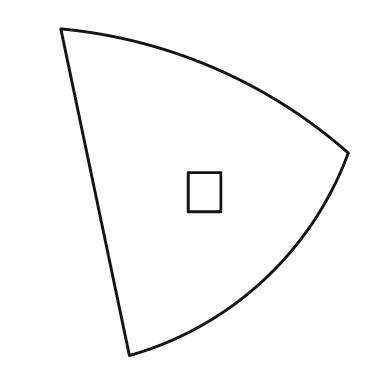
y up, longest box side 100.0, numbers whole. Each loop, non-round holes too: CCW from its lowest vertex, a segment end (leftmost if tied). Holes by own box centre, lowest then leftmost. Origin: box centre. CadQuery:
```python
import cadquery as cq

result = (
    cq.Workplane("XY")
    .moveTo(-23.0, -50.0)
    .threePointArc((18.0, -27.0), (44.0, 12.0))
    .threePointArc((3.0, 38.0), (-44.0, 50.0))
    .close()
    .moveTo(-5.0, -6.0)
    .lineTo(5.0, -6.0)
    .lineTo(5.0, 6.0)
    .lineTo(-5.0, 6.0)
    .close()
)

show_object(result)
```